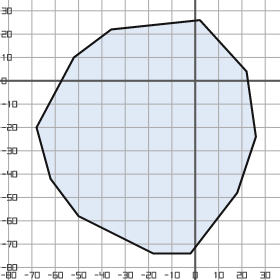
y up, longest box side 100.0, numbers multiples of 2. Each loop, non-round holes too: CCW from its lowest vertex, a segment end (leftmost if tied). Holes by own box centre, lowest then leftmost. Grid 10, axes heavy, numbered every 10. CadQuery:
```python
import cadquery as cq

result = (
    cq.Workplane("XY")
    .moveTo(-18.0, -74.0)
    .lineTo(-2.0, -74.0)
    .lineTo(18.0, -48.0)
    .lineTo(26.0, -24.0)
    .lineTo(22.0, 4.0)
    .lineTo(2.0, 26.0)
    .lineTo(-36.0, 22.0)
    .lineTo(-52.0, 10.0)
    .lineTo(-68.0, -20.0)
    .lineTo(-62.0, -42.0)
    .lineTo(-50.0, -58.0)
    .close()
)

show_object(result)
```